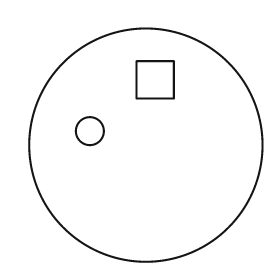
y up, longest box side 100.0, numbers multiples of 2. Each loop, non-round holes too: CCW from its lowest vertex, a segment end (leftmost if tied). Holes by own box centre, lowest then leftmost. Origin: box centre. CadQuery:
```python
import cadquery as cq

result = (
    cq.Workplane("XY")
    .moveTo(0.0, 0.0)
    .circle(50.0)
    .moveTo(-24.0, 6.0)
    .circle(6.0)
    .moveTo(-4.0, 20.0)
    .lineTo(12.0, 20.0)
    .lineTo(12.0, 36.0)
    .lineTo(-4.0, 36.0)
    .close()
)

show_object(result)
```